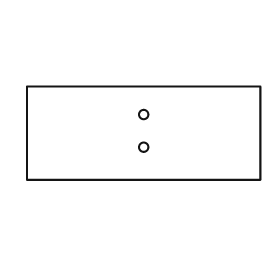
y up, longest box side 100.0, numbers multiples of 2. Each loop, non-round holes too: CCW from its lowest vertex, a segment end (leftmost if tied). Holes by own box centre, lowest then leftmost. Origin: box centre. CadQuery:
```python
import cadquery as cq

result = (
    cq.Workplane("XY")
    .moveTo(-50.0, -20.0)
    .lineTo(50.0, -20.0)
    .lineTo(50.0, 20.0)
    .lineTo(-50.0, 20.0)
    .close()
    .moveTo(0.0, -6.0)
    .circle(2.0)
    .moveTo(0.0, 8.0)
    .circle(2.0)
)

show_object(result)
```